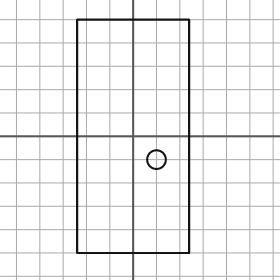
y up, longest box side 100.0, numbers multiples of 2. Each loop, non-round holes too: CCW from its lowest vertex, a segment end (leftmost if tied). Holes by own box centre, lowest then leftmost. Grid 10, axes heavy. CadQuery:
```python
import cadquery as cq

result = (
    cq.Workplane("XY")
    .moveTo(-24.0, -50.0)
    .lineTo(24.0, -50.0)
    .lineTo(24.0, 50.0)
    .lineTo(-24.0, 50.0)
    .close()
    .moveTo(10.0, -10.0)
    .circle(4.0)
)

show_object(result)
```